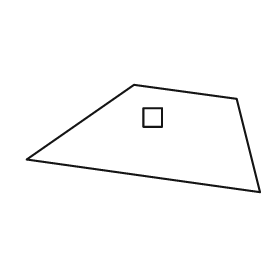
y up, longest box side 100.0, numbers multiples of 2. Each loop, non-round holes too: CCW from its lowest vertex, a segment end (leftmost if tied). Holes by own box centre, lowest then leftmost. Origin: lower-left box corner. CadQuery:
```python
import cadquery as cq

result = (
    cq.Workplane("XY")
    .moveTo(100.0, 0.0)
    .lineTo(90.0, 40.0)
    .lineTo(46.0, 46.0)
    .lineTo(0.0, 14.0)
    .close()
    .moveTo(50.0, 28.0)
    .lineTo(58.0, 28.0)
    .lineTo(58.0, 36.0)
    .lineTo(50.0, 36.0)
    .close()
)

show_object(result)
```